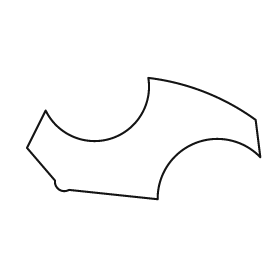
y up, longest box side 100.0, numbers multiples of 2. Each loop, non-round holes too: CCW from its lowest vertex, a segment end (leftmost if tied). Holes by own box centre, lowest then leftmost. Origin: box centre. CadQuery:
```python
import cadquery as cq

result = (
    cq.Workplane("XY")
    .moveTo(6.0, -26.0)
    .threePointArc((22.0, -2.0), (50.0, -8.0))
    .lineTo(48.0, 8.0)
    .threePointArc((26.0, 20.0), (2.0, 26.0))
    .threePointArc((-14.0, 0.0), (-42.0, 12.0))
    .lineTo(-50.0, -4.0)
    .lineTo(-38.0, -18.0)
    .threePointArc((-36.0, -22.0), (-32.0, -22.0))
    .close()
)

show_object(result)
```